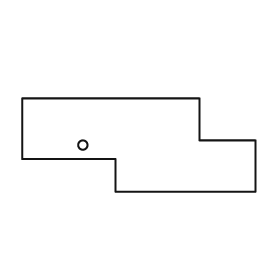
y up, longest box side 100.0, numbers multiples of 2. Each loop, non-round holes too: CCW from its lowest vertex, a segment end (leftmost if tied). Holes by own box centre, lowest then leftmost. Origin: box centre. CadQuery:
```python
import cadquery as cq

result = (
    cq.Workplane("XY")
    .moveTo(-10.0, -20.0)
    .lineTo(50.0, -20.0)
    .lineTo(50.0, 2.0)
    .lineTo(26.0, 2.0)
    .lineTo(26.0, 20.0)
    .lineTo(-50.0, 20.0)
    .lineTo(-50.0, -6.0)
    .lineTo(-10.0, -6.0)
    .close()
    .moveTo(-24.0, 0.0)
    .circle(2.0)
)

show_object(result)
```